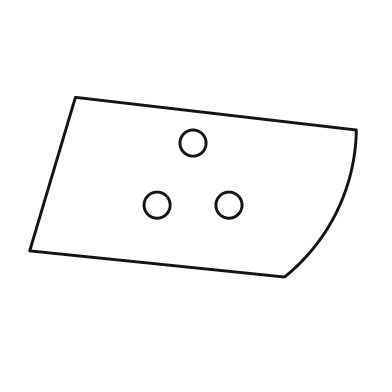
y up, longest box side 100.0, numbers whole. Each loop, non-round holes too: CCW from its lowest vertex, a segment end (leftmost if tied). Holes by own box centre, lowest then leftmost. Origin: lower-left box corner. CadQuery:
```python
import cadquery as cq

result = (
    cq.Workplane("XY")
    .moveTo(78.0, 0.0)
    .threePointArc((94.0, 20.0), (100.0, 45.0))
    .lineTo(14.0, 55.0)
    .lineTo(0.0, 8.0)
    .close()
    .moveTo(39.0, 22.0)
    .circle(4.0)
    .moveTo(61.0, 22.0)
    .circle(4.0)
    .moveTo(50.0, 41.0)
    .circle(4.0)
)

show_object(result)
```